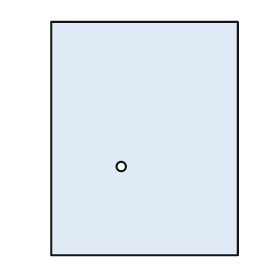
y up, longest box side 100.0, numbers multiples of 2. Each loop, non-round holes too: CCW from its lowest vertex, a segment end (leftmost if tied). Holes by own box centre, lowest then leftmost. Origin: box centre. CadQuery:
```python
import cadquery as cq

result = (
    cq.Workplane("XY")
    .moveTo(-40.0, -50.0)
    .lineTo(40.0, -50.0)
    .lineTo(40.0, 50.0)
    .lineTo(-40.0, 50.0)
    .close()
    .moveTo(-10.0, -12.0)
    .circle(2.0)
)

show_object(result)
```